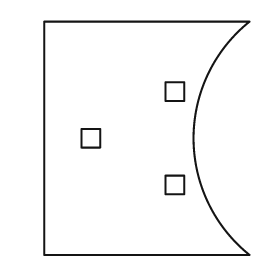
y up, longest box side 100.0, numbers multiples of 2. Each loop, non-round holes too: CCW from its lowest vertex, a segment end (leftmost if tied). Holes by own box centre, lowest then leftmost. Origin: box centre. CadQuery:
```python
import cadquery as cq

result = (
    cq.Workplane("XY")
    .moveTo(-44.0, -50.0)
    .lineTo(44.0, -50.0)
    .threePointArc((20.0, 0.0), (44.0, 50.0))
    .lineTo(-44.0, 50.0)
    .close()
    .moveTo(8.0, -24.0)
    .lineTo(16.0, -24.0)
    .lineTo(16.0, -16.0)
    .lineTo(8.0, -16.0)
    .close()
    .moveTo(-28.0, -4.0)
    .lineTo(-20.0, -4.0)
    .lineTo(-20.0, 4.0)
    .lineTo(-28.0, 4.0)
    .close()
    .moveTo(8.0, 16.0)
    .lineTo(16.0, 16.0)
    .lineTo(16.0, 24.0)
    .lineTo(8.0, 24.0)
    .close()
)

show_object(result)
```